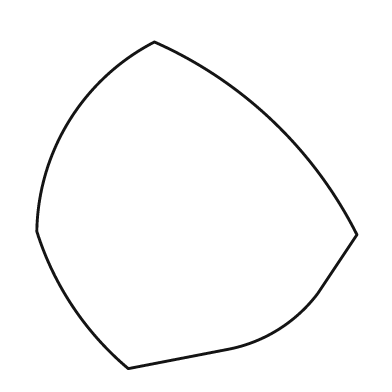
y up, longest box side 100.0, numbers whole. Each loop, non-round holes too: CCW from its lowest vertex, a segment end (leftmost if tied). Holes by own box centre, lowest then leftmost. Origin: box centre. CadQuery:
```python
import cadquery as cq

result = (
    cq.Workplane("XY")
    .moveTo(-21.0, -50.0)
    .lineTo(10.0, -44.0)
    .threePointArc((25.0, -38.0), (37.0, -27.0))
    .lineTo(49.0, -9.0)
    .threePointArc((23.0, 26.0), (-13.0, 50.0))
    .threePointArc((-39.0, 26.0), (-49.0, -8.0))
    .threePointArc((-38.0, -31.0), (-21.0, -50.0))
    .close()
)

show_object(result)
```